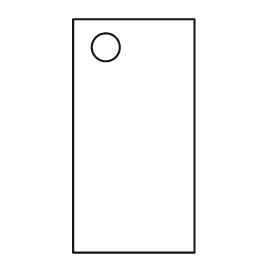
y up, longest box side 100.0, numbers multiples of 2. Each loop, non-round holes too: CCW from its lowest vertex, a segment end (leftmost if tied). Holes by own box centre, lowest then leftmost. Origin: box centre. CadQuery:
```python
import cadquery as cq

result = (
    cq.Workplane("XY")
    .moveTo(-26.0, -50.0)
    .lineTo(26.0, -50.0)
    .lineTo(26.0, 50.0)
    .lineTo(-26.0, 50.0)
    .close()
    .moveTo(-12.0, 38.0)
    .circle(6.0)
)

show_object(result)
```